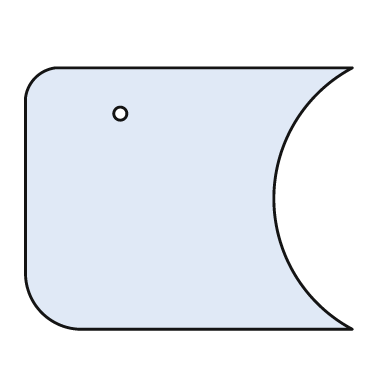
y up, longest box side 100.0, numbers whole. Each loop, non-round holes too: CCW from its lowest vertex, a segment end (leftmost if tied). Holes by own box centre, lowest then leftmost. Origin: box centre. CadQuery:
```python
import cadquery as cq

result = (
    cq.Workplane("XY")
    .moveTo(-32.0, -40.0)
    .lineTo(50.0, -40.0)
    .threePointArc((26.0, 0.0), (50.0, 40.0))
    .lineTo(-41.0, 40.0)
    .threePointArc((-47.0, 37.0), (-50.0, 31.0))
    .lineTo(-50.0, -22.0)
    .threePointArc((-45.0, -35.0), (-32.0, -40.0))
    .close()
    .moveTo(-21.0, 26.0)
    .circle(2.0)
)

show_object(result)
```